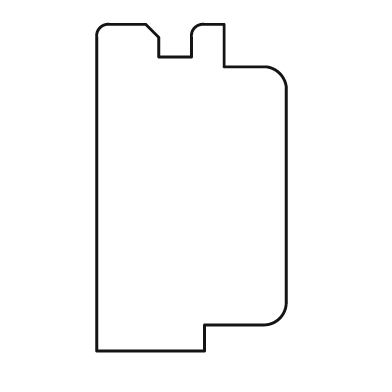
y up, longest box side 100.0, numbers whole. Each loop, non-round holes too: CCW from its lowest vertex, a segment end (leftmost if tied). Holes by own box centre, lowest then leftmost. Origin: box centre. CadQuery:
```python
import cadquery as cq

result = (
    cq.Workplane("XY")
    .moveTo(-29.0, -50.0)
    .lineTo(4.0, -50.0)
    .lineTo(4.0, -42.0)
    .lineTo(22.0, -42.0)
    .threePointArc((27.0, -40.0), (29.0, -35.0))
    .lineTo(29.0, 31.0)
    .threePointArc((27.0, 35.0), (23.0, 37.0))
    .lineTo(10.0, 37.0)
    .lineTo(10.0, 50.0)
    .lineTo(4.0, 50.0)
    .threePointArc((1.0, 49.0), (0.0, 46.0))
    .lineTo(0.0, 40.0)
    .lineTo(-10.0, 40.0)
    .lineTo(-10.0, 46.0)
    .lineTo(-14.0, 50.0)
    .lineTo(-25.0, 50.0)
    .threePointArc((-28.0, 49.0), (-29.0, 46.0))
    .close()
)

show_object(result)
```